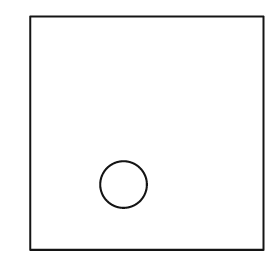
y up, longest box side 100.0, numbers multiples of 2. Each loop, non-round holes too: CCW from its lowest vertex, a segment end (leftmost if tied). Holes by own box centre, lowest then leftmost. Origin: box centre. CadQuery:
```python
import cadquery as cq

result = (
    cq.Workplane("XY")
    .moveTo(-50.0, -50.0)
    .lineTo(50.0, -50.0)
    .lineTo(50.0, 50.0)
    .lineTo(-50.0, 50.0)
    .close()
    .moveTo(-10.0, -22.0)
    .circle(10.0)
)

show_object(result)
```